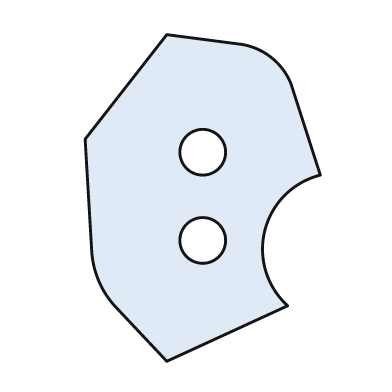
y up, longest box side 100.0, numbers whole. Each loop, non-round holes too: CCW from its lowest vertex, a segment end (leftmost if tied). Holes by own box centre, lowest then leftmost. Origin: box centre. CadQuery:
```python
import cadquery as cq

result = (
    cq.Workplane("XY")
    .moveTo(-11.0, -50.0)
    .lineTo(26.0, -33.0)
    .threePointArc((19.0, -10.0), (36.0, 7.0))
    .lineTo(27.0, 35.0)
    .threePointArc((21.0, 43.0), (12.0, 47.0))
    .lineTo(-11.0, 50.0)
    .lineTo(-36.0, 18.0)
    .lineTo(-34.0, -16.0)
    .threePointArc((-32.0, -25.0), (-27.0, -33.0))
    .close()
    .moveTo(0.0, -13.0)
    .circle(7.0)
    .moveTo(0.0, 14.0)
    .circle(7.0)
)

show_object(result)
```